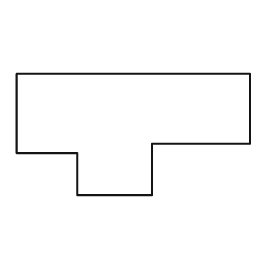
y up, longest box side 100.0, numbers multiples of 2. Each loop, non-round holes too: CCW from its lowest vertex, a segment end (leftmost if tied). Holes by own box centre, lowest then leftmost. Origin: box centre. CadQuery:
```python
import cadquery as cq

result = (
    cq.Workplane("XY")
    .moveTo(-24.0, -26.0)
    .lineTo(8.0, -26.0)
    .lineTo(8.0, -4.0)
    .lineTo(50.0, -4.0)
    .lineTo(50.0, 26.0)
    .lineTo(-50.0, 26.0)
    .lineTo(-50.0, -8.0)
    .lineTo(-24.0, -8.0)
    .close()
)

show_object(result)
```